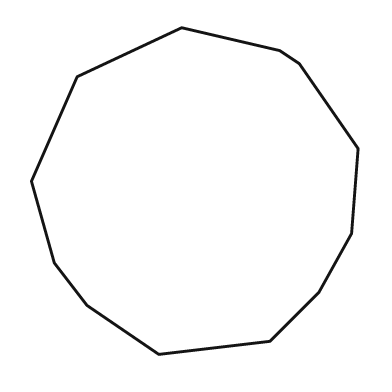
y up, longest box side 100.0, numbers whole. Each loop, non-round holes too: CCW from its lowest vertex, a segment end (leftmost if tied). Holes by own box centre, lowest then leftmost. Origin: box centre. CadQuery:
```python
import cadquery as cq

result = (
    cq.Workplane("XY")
    .moveTo(-11.0, -50.0)
    .lineTo(23.0, -46.0)
    .lineTo(38.0, -31.0)
    .lineTo(48.0, -13.0)
    .lineTo(50.0, 13.0)
    .lineTo(32.0, 39.0)
    .lineTo(26.0, 43.0)
    .lineTo(-4.0, 50.0)
    .lineTo(-36.0, 35.0)
    .lineTo(-50.0, 3.0)
    .lineTo(-43.0, -22.0)
    .lineTo(-33.0, -35.0)
    .close()
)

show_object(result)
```